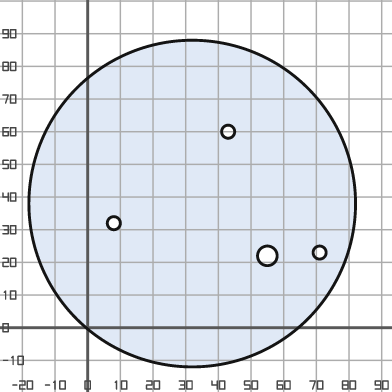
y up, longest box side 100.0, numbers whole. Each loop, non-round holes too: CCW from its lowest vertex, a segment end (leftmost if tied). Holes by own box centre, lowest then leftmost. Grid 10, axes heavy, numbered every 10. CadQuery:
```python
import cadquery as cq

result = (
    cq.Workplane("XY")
    .moveTo(32.0, 38.0)
    .circle(50.0)
    .moveTo(55.0, 22.0)
    .circle(3.0)
    .moveTo(71.0, 23.0)
    .circle(2.0)
    .moveTo(8.0, 32.0)
    .circle(2.0)
    .moveTo(43.0, 60.0)
    .circle(2.0)
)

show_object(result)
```